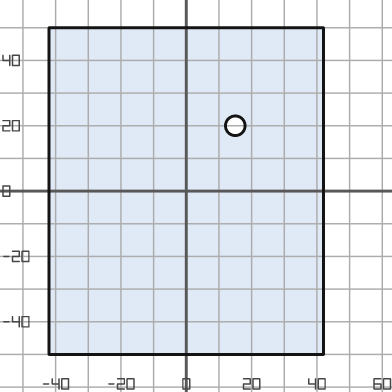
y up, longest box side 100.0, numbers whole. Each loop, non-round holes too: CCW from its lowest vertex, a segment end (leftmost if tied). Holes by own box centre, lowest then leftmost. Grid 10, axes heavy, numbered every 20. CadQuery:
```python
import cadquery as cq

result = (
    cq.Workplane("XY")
    .moveTo(-42.0, -50.0)
    .lineTo(42.0, -50.0)
    .lineTo(42.0, 50.0)
    .lineTo(-42.0, 50.0)
    .close()
    .moveTo(15.0, 20.0)
    .circle(3.0)
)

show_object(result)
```